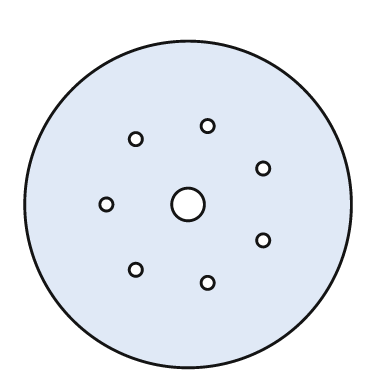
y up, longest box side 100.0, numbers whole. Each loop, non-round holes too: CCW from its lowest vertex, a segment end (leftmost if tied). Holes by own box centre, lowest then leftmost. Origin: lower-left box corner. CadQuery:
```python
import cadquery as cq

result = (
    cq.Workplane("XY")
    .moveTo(50.0, 50.0)
    .circle(50.0)
    .moveTo(56.0, 26.0)
    .circle(2.0)
    .moveTo(34.0, 30.0)
    .circle(2.0)
    .moveTo(73.0, 39.0)
    .circle(2.0)
    .moveTo(25.0, 50.0)
    .circle(2.0)
    .moveTo(50.0, 50.0)
    .circle(5.0)
    .moveTo(73.0, 61.0)
    .circle(2.0)
    .moveTo(34.0, 70.0)
    .circle(2.0)
    .moveTo(56.0, 74.0)
    .circle(2.0)
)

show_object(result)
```